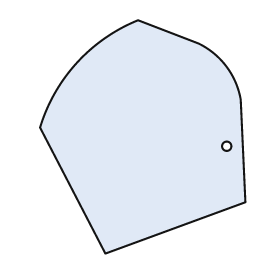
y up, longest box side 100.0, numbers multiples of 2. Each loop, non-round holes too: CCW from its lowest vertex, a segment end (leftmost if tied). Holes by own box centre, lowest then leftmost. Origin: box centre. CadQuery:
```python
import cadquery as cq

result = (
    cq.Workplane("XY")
    .moveTo(-16.0, -50.0)
    .lineTo(44.0, -28.0)
    .lineTo(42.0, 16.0)
    .threePointArc((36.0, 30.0), (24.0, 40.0))
    .lineTo(-2.0, 50.0)
    .threePointArc((-28.0, 32.0), (-44.0, 4.0))
    .close()
    .moveTo(36.0, -4.0)
    .circle(2.0)
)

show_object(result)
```